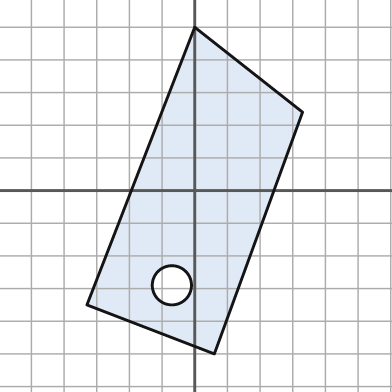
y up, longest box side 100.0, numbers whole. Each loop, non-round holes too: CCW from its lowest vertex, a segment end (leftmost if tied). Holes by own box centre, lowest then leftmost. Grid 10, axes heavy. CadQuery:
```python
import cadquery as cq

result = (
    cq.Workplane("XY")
    .moveTo(6.0, -50.0)
    .lineTo(33.0, 24.0)
    .lineTo(0.0, 50.0)
    .lineTo(-33.0, -35.0)
    .close()
    .moveTo(-7.0, -29.0)
    .circle(6.0)
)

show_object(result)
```